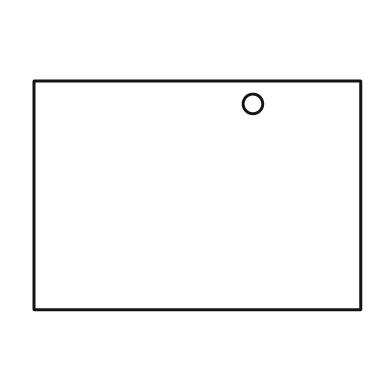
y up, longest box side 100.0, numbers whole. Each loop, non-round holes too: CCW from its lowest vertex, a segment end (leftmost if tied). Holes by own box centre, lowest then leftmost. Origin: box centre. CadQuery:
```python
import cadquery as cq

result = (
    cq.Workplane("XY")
    .moveTo(-50.0, -35.0)
    .lineTo(50.0, -35.0)
    .lineTo(50.0, 35.0)
    .lineTo(-50.0, 35.0)
    .close()
    .moveTo(17.0, 28.0)
    .circle(3.0)
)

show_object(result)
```